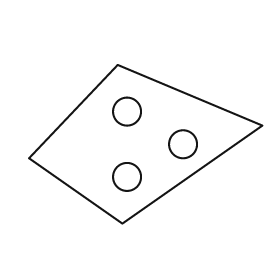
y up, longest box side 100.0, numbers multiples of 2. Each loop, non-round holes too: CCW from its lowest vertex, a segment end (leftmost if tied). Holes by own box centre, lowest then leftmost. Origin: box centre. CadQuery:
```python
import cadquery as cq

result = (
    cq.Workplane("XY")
    .moveTo(-10.0, -34.0)
    .lineTo(50.0, 8.0)
    .lineTo(-12.0, 34.0)
    .lineTo(-50.0, -6.0)
    .close()
    .moveTo(-8.0, -14.0)
    .circle(6.0)
    .moveTo(16.0, 0.0)
    .circle(6.0)
    .moveTo(-8.0, 14.0)
    .circle(6.0)
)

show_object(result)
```